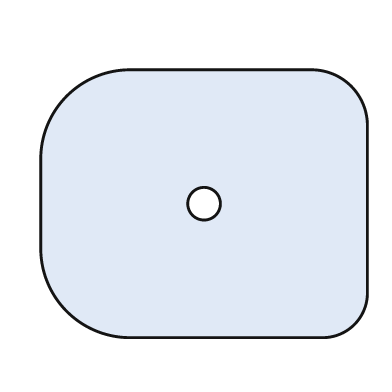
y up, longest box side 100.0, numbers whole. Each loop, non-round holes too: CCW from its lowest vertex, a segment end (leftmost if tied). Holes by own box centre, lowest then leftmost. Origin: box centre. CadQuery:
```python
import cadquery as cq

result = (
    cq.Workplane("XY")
    .moveTo(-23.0, -41.0)
    .lineTo(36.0, -41.0)
    .threePointArc((46.0, -37.0), (50.0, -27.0))
    .lineTo(50.0, 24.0)
    .threePointArc((45.0, 36.0), (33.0, 41.0))
    .lineTo(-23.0, 41.0)
    .threePointArc((-42.0, 33.0), (-50.0, 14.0))
    .lineTo(-50.0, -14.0)
    .threePointArc((-42.0, -33.0), (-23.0, -41.0))
    .close()
    .moveTo(0.0, 0.0)
    .circle(5.0)
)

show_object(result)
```